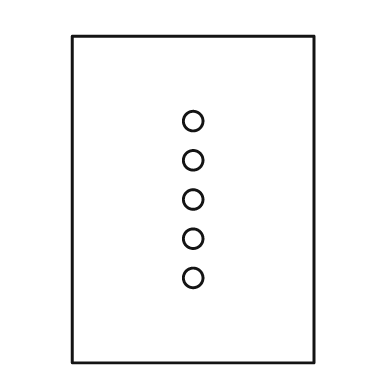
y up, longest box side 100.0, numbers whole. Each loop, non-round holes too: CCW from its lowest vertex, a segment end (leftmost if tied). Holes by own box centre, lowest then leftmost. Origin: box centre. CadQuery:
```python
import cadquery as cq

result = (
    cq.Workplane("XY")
    .moveTo(-37.0, -50.0)
    .lineTo(37.0, -50.0)
    .lineTo(37.0, 50.0)
    .lineTo(-37.0, 50.0)
    .close()
    .moveTo(0.0, -24.0)
    .circle(3.0)
    .moveTo(0.0, -12.0)
    .circle(3.0)
    .moveTo(0.0, 0.0)
    .circle(3.0)
    .moveTo(0.0, 12.0)
    .circle(3.0)
    .moveTo(0.0, 24.0)
    .circle(3.0)
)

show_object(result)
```